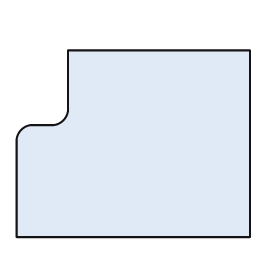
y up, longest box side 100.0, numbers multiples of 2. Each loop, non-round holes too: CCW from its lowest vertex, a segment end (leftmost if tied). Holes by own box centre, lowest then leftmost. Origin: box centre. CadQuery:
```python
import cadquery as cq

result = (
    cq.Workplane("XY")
    .moveTo(-50.0, -40.0)
    .lineTo(50.0, -40.0)
    .lineTo(50.0, 40.0)
    .lineTo(-28.0, 40.0)
    .lineTo(-28.0, 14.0)
    .threePointArc((-30.0, 10.0), (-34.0, 8.0))
    .lineTo(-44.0, 8.0)
    .threePointArc((-48.0, 6.0), (-50.0, 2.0))
    .close()
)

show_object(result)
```